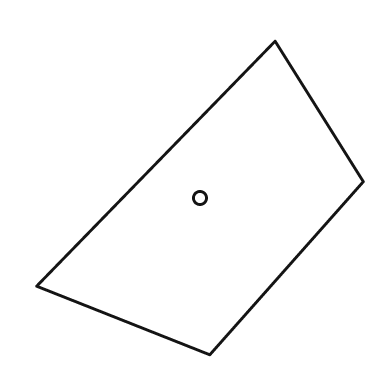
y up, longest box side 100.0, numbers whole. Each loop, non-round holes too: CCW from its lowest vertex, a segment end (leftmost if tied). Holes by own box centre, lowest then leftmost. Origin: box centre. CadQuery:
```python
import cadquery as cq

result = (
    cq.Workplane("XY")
    .moveTo(3.0, -48.0)
    .lineTo(50.0, 5.0)
    .lineTo(23.0, 48.0)
    .lineTo(-50.0, -27.0)
    .close()
    .moveTo(0.0, 0.0)
    .circle(2.0)
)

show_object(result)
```